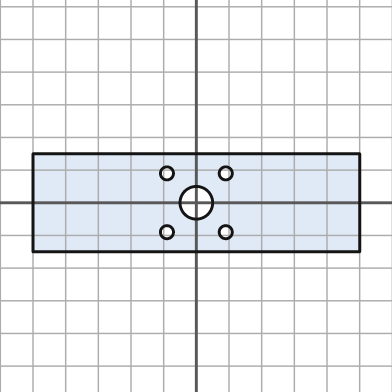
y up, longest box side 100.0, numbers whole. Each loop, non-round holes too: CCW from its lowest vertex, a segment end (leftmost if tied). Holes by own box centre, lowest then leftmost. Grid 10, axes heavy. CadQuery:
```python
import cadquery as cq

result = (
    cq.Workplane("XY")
    .moveTo(-50.0, -15.0)
    .lineTo(50.0, -15.0)
    .lineTo(50.0, 15.0)
    .lineTo(-50.0, 15.0)
    .close()
    .moveTo(-9.0, -9.0)
    .circle(2.0)
    .moveTo(9.0, -9.0)
    .circle(2.0)
    .moveTo(0.0, 0.0)
    .circle(5.0)
    .moveTo(-9.0, 9.0)
    .circle(2.0)
    .moveTo(9.0, 9.0)
    .circle(2.0)
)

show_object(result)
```